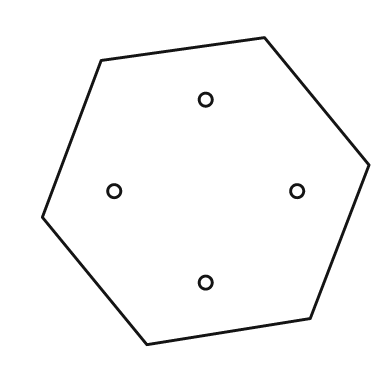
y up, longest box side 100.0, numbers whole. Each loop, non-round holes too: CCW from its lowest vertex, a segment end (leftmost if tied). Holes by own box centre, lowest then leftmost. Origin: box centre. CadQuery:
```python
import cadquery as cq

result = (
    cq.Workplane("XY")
    .moveTo(-18.0, -47.0)
    .lineTo(32.0, -39.0)
    .lineTo(50.0, 8.0)
    .lineTo(18.0, 47.0)
    .lineTo(-32.0, 40.0)
    .lineTo(-50.0, -8.0)
    .close()
    .moveTo(0.0, -28.0)
    .circle(2.0)
    .moveTo(-28.0, 0.0)
    .circle(2.0)
    .moveTo(28.0, 0.0)
    .circle(2.0)
    .moveTo(0.0, 28.0)
    .circle(2.0)
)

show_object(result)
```